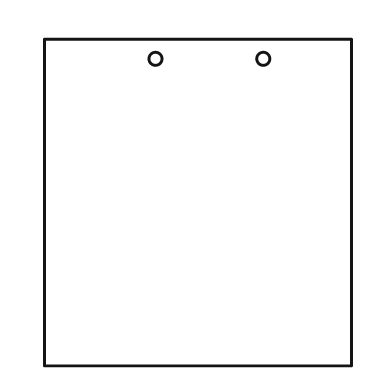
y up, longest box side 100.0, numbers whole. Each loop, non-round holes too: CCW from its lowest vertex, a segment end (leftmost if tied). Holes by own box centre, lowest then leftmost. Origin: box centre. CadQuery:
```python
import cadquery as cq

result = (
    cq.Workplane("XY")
    .moveTo(-47.0, -50.0)
    .lineTo(47.0, -50.0)
    .lineTo(47.0, 50.0)
    .lineTo(-47.0, 50.0)
    .close()
    .moveTo(-13.0, 44.0)
    .circle(2.0)
    .moveTo(20.0, 44.0)
    .circle(2.0)
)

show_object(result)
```